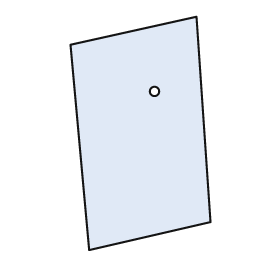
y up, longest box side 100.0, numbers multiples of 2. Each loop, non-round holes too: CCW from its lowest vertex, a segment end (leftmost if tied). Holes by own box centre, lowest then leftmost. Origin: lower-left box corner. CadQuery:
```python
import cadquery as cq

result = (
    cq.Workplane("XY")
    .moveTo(8.0, 0.0)
    .lineTo(60.0, 12.0)
    .lineTo(54.0, 100.0)
    .lineTo(0.0, 88.0)
    .close()
    .moveTo(36.0, 68.0)
    .circle(2.0)
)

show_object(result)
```